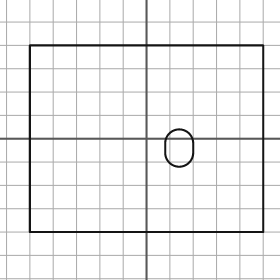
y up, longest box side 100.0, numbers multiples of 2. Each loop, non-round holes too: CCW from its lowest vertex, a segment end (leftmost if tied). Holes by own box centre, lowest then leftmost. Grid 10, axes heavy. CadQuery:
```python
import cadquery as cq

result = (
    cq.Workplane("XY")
    .moveTo(-50.0, -40.0)
    .lineTo(50.0, -40.0)
    .lineTo(50.0, 40.0)
    .lineTo(-50.0, 40.0)
    .close()
    .moveTo(8.0, -6.0)
    .threePointArc((14.0, -12.0), (20.0, -6.0))
    .lineTo(20.0, -2.0)
    .threePointArc((14.0, 4.0), (8.0, -2.0))
    .close()
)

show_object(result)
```